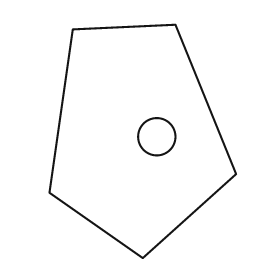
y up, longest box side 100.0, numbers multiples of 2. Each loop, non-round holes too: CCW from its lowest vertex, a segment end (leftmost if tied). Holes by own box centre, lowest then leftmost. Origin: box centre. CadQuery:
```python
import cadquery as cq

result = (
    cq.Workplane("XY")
    .moveTo(0.0, -50.0)
    .lineTo(40.0, -14.0)
    .lineTo(14.0, 50.0)
    .lineTo(-30.0, 48.0)
    .lineTo(-40.0, -22.0)
    .close()
    .moveTo(6.0, 2.0)
    .circle(8.0)
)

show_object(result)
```